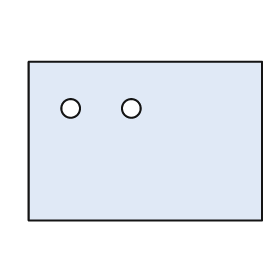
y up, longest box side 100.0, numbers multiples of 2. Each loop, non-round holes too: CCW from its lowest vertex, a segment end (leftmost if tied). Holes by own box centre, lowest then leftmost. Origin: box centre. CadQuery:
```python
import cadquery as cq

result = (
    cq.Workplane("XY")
    .moveTo(-50.0, -34.0)
    .lineTo(50.0, -34.0)
    .lineTo(50.0, 34.0)
    .lineTo(-50.0, 34.0)
    .close()
    .moveTo(-32.0, 14.0)
    .circle(4.0)
    .moveTo(-6.0, 14.0)
    .circle(4.0)
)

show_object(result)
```